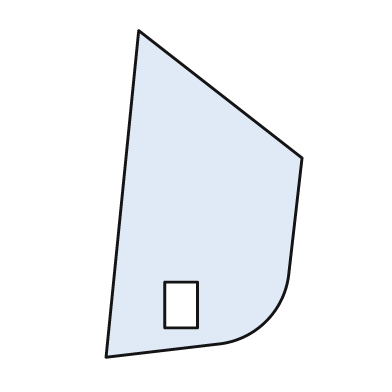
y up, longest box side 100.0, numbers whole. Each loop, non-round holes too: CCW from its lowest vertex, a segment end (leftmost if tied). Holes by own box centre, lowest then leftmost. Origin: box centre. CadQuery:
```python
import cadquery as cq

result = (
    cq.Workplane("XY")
    .moveTo(-30.0, -50.0)
    .lineTo(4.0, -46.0)
    .threePointArc((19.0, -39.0), (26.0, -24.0))
    .lineTo(30.0, 11.0)
    .lineTo(-20.0, 50.0)
    .close()
    .moveTo(-12.0, -41.0)
    .lineTo(-2.0, -41.0)
    .lineTo(-2.0, -27.0)
    .lineTo(-12.0, -27.0)
    .close()
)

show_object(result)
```